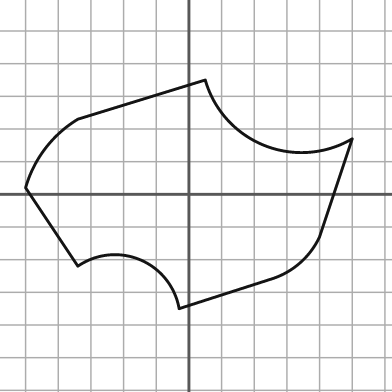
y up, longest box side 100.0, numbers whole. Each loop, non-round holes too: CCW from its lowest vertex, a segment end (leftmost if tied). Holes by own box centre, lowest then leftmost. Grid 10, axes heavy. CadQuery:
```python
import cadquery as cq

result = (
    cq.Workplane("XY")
    .moveTo(-3.0, -35.0)
    .lineTo(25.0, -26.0)
    .threePointArc((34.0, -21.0), (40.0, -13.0))
    .lineTo(50.0, 17.0)
    .threePointArc((23.0, 15.0), (5.0, 35.0))
    .lineTo(-34.0, 23.0)
    .threePointArc((-44.0, 14.0), (-50.0, 2.0))
    .lineTo(-34.0, -22.0)
    .threePointArc((-15.0, -20.0), (-3.0, -35.0))
    .close()
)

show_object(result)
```